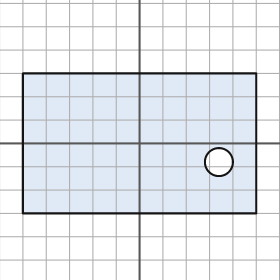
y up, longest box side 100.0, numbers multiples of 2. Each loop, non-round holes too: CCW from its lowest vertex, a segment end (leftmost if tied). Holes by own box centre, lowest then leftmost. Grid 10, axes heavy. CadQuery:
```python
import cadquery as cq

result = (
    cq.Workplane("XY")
    .moveTo(-50.0, -30.0)
    .lineTo(50.0, -30.0)
    .lineTo(50.0, 30.0)
    .lineTo(-50.0, 30.0)
    .close()
    .moveTo(34.0, -8.0)
    .circle(6.0)
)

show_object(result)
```